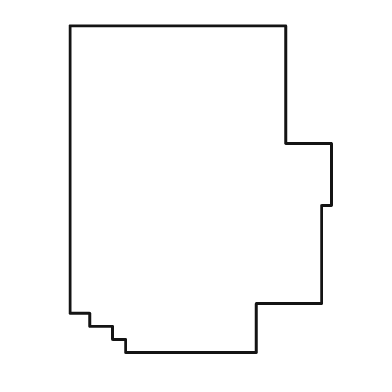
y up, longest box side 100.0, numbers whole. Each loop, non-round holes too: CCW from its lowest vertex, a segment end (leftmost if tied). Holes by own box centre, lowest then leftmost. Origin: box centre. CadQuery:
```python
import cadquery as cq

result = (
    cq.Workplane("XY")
    .moveTo(-23.0, -50.0)
    .lineTo(17.0, -50.0)
    .lineTo(17.0, -35.0)
    .lineTo(37.0, -35.0)
    .lineTo(37.0, -5.0)
    .lineTo(40.0, -5.0)
    .lineTo(40.0, 14.0)
    .lineTo(26.0, 14.0)
    .lineTo(26.0, 50.0)
    .lineTo(-40.0, 50.0)
    .lineTo(-40.0, -38.0)
    .lineTo(-34.0, -38.0)
    .lineTo(-34.0, -42.0)
    .lineTo(-27.0, -42.0)
    .lineTo(-27.0, -46.0)
    .lineTo(-23.0, -46.0)
    .close()
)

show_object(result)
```